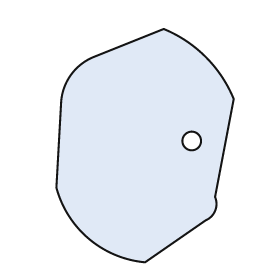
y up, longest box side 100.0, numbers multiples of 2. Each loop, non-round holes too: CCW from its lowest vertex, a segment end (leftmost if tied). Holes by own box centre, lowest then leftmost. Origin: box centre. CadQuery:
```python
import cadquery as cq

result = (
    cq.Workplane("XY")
    .moveTo(0.0, -50.0)
    .lineTo(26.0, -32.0)
    .threePointArc((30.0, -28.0), (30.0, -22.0))
    .lineTo(38.0, 20.0)
    .threePointArc((26.0, 38.0), (8.0, 50.0))
    .lineTo(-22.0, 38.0)
    .threePointArc((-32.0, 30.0), (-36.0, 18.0))
    .lineTo(-38.0, -18.0)
    .threePointArc((-24.0, -40.0), (0.0, -50.0))
    .close()
    .moveTo(20.0, 2.0)
    .circle(4.0)
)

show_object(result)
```